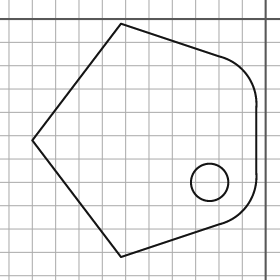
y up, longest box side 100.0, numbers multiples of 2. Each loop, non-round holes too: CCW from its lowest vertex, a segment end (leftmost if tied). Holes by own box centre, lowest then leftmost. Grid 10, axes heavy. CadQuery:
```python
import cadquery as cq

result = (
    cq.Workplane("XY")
    .moveTo(-62.0, -102.0)
    .lineTo(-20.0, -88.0)
    .threePointArc((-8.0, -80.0), (-4.0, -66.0))
    .lineTo(-4.0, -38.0)
    .threePointArc((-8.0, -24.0), (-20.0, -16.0))
    .lineTo(-62.0, -2.0)
    .lineTo(-100.0, -52.0)
    .close()
    .moveTo(-24.0, -70.0)
    .circle(8.0)
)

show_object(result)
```